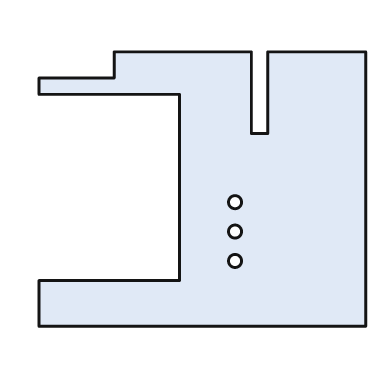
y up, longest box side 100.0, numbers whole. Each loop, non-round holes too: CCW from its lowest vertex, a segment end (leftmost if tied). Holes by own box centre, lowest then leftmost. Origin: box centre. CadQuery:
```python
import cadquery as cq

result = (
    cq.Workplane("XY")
    .moveTo(-50.0, -42.0)
    .lineTo(50.0, -42.0)
    .lineTo(50.0, 42.0)
    .lineTo(20.0, 42.0)
    .lineTo(20.0, 17.0)
    .lineTo(15.0, 17.0)
    .lineTo(15.0, 42.0)
    .lineTo(-27.0, 42.0)
    .lineTo(-27.0, 34.0)
    .lineTo(-50.0, 34.0)
    .lineTo(-50.0, 29.0)
    .lineTo(-7.0, 29.0)
    .lineTo(-7.0, -28.0)
    .lineTo(-50.0, -28.0)
    .close()
    .moveTo(10.0, -22.0)
    .circle(2.0)
    .moveTo(10.0, -13.0)
    .circle(2.0)
    .moveTo(10.0, -4.0)
    .circle(2.0)
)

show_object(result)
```